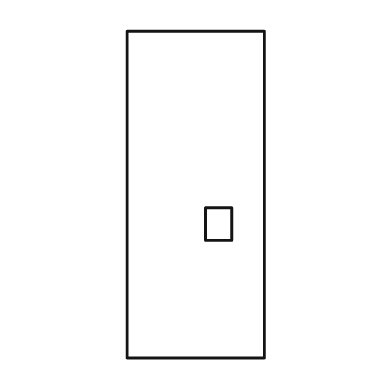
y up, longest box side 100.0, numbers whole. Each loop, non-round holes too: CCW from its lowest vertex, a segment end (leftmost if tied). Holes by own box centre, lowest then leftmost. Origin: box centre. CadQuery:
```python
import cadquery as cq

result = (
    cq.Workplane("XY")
    .moveTo(-21.0, -50.0)
    .lineTo(21.0, -50.0)
    .lineTo(21.0, 50.0)
    .lineTo(-21.0, 50.0)
    .close()
    .moveTo(3.0, -14.0)
    .lineTo(11.0, -14.0)
    .lineTo(11.0, -4.0)
    .lineTo(3.0, -4.0)
    .close()
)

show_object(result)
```